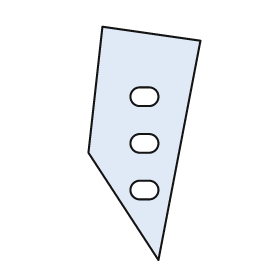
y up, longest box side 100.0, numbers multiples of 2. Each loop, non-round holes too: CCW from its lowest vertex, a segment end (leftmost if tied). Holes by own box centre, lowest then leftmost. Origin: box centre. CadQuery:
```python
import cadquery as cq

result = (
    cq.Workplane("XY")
    .moveTo(6.0, -50.0)
    .lineTo(24.0, 44.0)
    .lineTo(-18.0, 50.0)
    .lineTo(-24.0, -4.0)
    .close()
    .moveTo(-2.0, -24.0)
    .lineTo(2.0, -24.0)
    .threePointArc((6.0, -20.0), (2.0, -16.0))
    .lineTo(-2.0, -16.0)
    .threePointArc((-6.0, -20.0), (-2.0, -24.0))
    .close()
    .moveTo(-2.0, -4.0)
    .lineTo(2.0, -4.0)
    .threePointArc((6.0, 0.0), (2.0, 4.0))
    .lineTo(-2.0, 4.0)
    .threePointArc((-6.0, 0.0), (-2.0, -4.0))
    .close()
    .moveTo(-2.0, 16.0)
    .lineTo(2.0, 16.0)
    .threePointArc((6.0, 20.0), (2.0, 24.0))
    .lineTo(-2.0, 24.0)
    .threePointArc((-6.0, 20.0), (-2.0, 16.0))
    .close()
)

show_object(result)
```